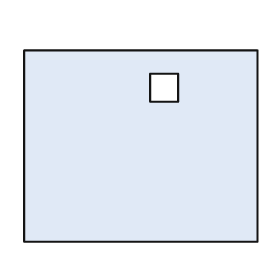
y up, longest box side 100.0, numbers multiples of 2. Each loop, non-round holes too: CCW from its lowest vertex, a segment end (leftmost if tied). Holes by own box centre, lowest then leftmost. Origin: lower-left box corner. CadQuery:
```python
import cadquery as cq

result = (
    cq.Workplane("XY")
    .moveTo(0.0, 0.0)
    .lineTo(100.0, 0.0)
    .lineTo(100.0, 82.0)
    .lineTo(0.0, 82.0)
    .close()
    .moveTo(54.0, 60.0)
    .lineTo(66.0, 60.0)
    .lineTo(66.0, 72.0)
    .lineTo(54.0, 72.0)
    .close()
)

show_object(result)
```